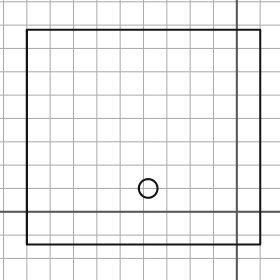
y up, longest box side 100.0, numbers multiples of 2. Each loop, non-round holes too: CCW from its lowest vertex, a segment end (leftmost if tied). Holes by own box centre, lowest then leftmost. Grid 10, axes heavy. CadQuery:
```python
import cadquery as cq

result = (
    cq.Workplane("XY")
    .moveTo(-90.0, -14.0)
    .lineTo(10.0, -14.0)
    .lineTo(10.0, 78.0)
    .lineTo(-90.0, 78.0)
    .close()
    .moveTo(-38.0, 10.0)
    .circle(4.0)
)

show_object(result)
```